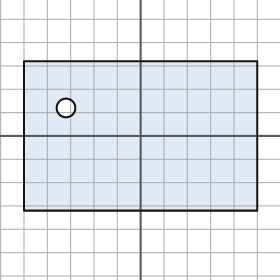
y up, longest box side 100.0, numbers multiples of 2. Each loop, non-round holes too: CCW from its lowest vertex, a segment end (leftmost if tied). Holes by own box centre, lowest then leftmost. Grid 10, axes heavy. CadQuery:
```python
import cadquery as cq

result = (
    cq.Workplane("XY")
    .moveTo(-50.0, -32.0)
    .lineTo(50.0, -32.0)
    .lineTo(50.0, 32.0)
    .lineTo(-50.0, 32.0)
    .close()
    .moveTo(-32.0, 12.0)
    .circle(4.0)
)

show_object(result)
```